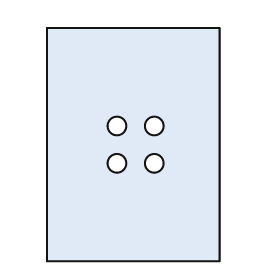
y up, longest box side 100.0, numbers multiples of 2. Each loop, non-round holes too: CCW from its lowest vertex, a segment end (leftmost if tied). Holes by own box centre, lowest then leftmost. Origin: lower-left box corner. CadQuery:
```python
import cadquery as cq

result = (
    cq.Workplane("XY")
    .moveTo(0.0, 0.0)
    .lineTo(74.0, 0.0)
    .lineTo(74.0, 100.0)
    .lineTo(0.0, 100.0)
    .close()
    .moveTo(30.0, 42.0)
    .circle(4.0)
    .moveTo(46.0, 42.0)
    .circle(4.0)
    .moveTo(30.0, 58.0)
    .circle(4.0)
    .moveTo(46.0, 58.0)
    .circle(4.0)
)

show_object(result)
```